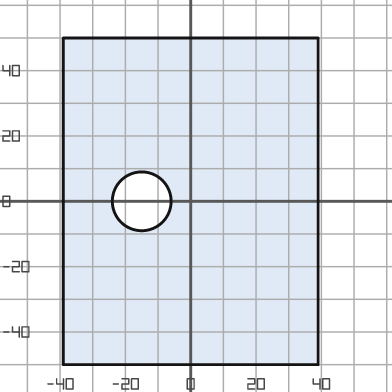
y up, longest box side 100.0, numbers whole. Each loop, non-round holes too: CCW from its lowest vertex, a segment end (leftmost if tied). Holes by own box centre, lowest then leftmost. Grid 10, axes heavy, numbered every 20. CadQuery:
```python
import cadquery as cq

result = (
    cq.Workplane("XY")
    .moveTo(-39.0, -50.0)
    .lineTo(39.0, -50.0)
    .lineTo(39.0, 50.0)
    .lineTo(-39.0, 50.0)
    .close()
    .moveTo(-15.0, 0.0)
    .circle(9.0)
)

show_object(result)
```